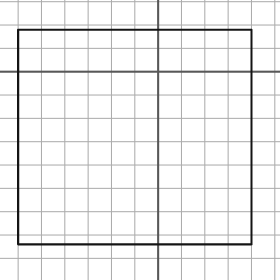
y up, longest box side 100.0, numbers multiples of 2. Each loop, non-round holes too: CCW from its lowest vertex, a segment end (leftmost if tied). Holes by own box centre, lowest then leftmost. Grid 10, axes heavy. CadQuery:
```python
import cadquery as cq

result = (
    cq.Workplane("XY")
    .moveTo(-60.0, -74.0)
    .lineTo(40.0, -74.0)
    .lineTo(40.0, 18.0)
    .lineTo(-60.0, 18.0)
    .close()
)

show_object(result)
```